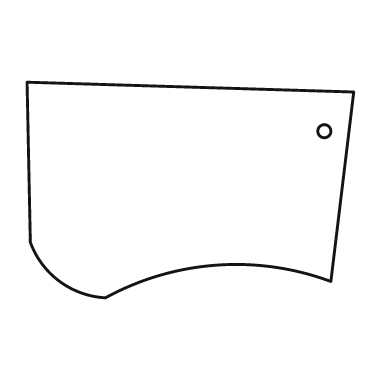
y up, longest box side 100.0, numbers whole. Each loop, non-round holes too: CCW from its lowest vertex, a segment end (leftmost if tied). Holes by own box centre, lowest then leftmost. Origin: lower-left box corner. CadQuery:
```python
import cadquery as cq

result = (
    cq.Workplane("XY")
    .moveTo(24.0, 0.0)
    .threePointArc((58.0, 10.0), (93.0, 5.0))
    .lineTo(100.0, 63.0)
    .lineTo(0.0, 66.0)
    .lineTo(1.0, 17.0)
    .threePointArc((10.0, 5.0), (24.0, 0.0))
    .close()
    .moveTo(91.0, 51.0)
    .circle(2.0)
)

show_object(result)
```